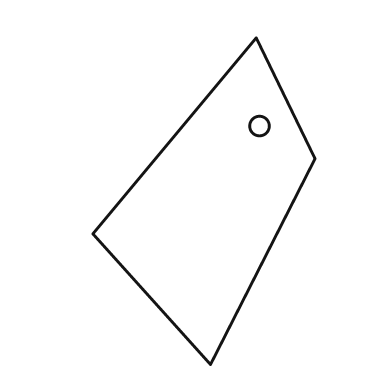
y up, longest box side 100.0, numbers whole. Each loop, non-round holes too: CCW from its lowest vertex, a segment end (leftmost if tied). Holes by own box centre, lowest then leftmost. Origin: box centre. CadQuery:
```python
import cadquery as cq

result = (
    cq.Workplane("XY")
    .moveTo(2.0, -50.0)
    .lineTo(34.0, 13.0)
    .lineTo(16.0, 50.0)
    .lineTo(-34.0, -10.0)
    .close()
    .moveTo(17.0, 23.0)
    .circle(3.0)
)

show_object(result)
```